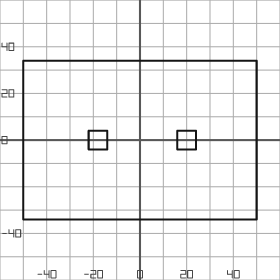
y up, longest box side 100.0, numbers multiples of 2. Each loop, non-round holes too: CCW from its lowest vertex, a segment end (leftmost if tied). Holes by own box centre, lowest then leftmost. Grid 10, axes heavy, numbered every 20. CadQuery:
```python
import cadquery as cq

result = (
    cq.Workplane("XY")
    .moveTo(-50.0, -34.0)
    .lineTo(50.0, -34.0)
    .lineTo(50.0, 34.0)
    .lineTo(-50.0, 34.0)
    .close()
    .moveTo(-22.0, -4.0)
    .lineTo(-14.0, -4.0)
    .lineTo(-14.0, 4.0)
    .lineTo(-22.0, 4.0)
    .close()
    .moveTo(16.0, -4.0)
    .lineTo(24.0, -4.0)
    .lineTo(24.0, 4.0)
    .lineTo(16.0, 4.0)
    .close()
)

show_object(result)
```